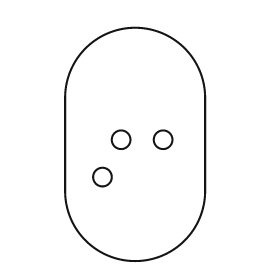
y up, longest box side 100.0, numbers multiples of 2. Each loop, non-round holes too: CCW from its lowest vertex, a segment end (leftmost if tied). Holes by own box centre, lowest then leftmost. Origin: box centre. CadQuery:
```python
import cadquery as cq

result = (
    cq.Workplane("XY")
    .moveTo(-30.0, -20.0)
    .threePointArc((0.0, -50.0), (30.0, -20.0))
    .lineTo(30.0, 20.0)
    .threePointArc((0.0, 50.0), (-30.0, 20.0))
    .close()
    .moveTo(-14.0, -14.0)
    .circle(4.0)
    .moveTo(-6.0, 2.0)
    .circle(4.0)
    .moveTo(12.0, 2.0)
    .circle(4.0)
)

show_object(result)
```